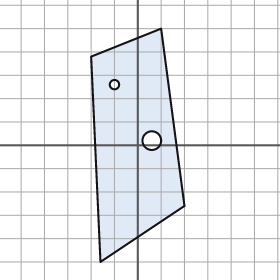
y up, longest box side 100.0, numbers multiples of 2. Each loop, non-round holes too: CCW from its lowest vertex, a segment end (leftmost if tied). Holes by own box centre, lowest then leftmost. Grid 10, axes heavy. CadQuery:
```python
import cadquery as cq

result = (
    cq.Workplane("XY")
    .moveTo(-16.0, -50.0)
    .lineTo(20.0, -26.0)
    .lineTo(10.0, 50.0)
    .lineTo(-20.0, 38.0)
    .close()
    .moveTo(6.0, 2.0)
    .circle(4.0)
    .moveTo(-10.0, 26.0)
    .circle(2.0)
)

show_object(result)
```